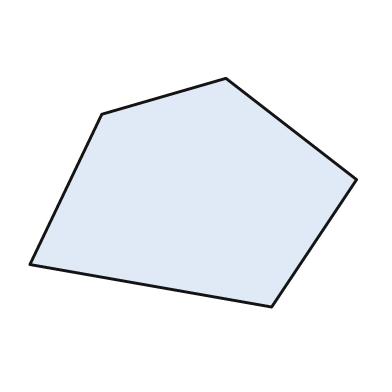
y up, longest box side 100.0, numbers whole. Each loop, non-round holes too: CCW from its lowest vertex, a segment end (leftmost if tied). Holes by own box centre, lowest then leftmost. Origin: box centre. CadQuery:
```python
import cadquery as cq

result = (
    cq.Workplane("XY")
    .moveTo(24.0, -35.0)
    .lineTo(50.0, 4.0)
    .lineTo(10.0, 35.0)
    .lineTo(-28.0, 24.0)
    .lineTo(-50.0, -22.0)
    .close()
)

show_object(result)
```